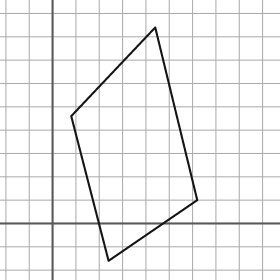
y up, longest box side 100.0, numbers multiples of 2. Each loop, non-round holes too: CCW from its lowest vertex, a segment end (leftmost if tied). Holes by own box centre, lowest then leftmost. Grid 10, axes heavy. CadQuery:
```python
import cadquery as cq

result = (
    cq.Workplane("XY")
    .moveTo(24.0, -16.0)
    .lineTo(62.0, 10.0)
    .lineTo(44.0, 84.0)
    .lineTo(8.0, 46.0)
    .close()
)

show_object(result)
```